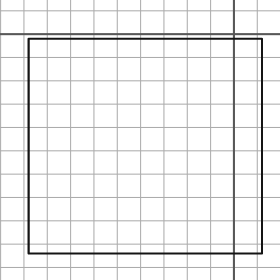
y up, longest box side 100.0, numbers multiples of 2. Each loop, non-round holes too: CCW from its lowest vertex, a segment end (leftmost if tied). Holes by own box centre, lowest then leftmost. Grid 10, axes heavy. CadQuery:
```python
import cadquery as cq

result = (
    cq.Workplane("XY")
    .moveTo(-88.0, -94.0)
    .lineTo(12.0, -94.0)
    .lineTo(12.0, -2.0)
    .lineTo(-88.0, -2.0)
    .close()
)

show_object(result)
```